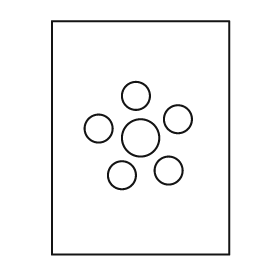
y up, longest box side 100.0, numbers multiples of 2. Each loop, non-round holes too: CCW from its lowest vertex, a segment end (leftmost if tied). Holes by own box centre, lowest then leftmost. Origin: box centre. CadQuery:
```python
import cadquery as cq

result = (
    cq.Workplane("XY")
    .moveTo(-38.0, -50.0)
    .lineTo(38.0, -50.0)
    .lineTo(38.0, 50.0)
    .lineTo(-38.0, 50.0)
    .close()
    .moveTo(-8.0, -16.0)
    .circle(6.0)
    .moveTo(12.0, -14.0)
    .circle(6.0)
    .moveTo(0.0, 0.0)
    .circle(8.0)
    .moveTo(-18.0, 4.0)
    .circle(6.0)
    .moveTo(16.0, 8.0)
    .circle(6.0)
    .moveTo(-2.0, 18.0)
    .circle(6.0)
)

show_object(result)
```